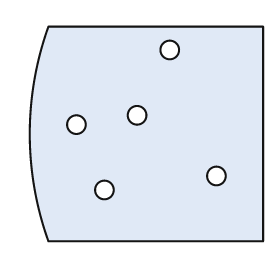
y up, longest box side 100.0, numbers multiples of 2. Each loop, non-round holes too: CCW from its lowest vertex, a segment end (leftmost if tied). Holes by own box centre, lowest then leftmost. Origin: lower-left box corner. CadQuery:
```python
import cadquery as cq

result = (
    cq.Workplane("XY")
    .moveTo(8.0, 0.0)
    .lineTo(100.0, 0.0)
    .lineTo(100.0, 92.0)
    .lineTo(8.0, 92.0)
    .threePointArc((0.0, 46.0), (8.0, 0.0))
    .close()
    .moveTo(32.0, 22.0)
    .circle(4.0)
    .moveTo(80.0, 28.0)
    .circle(4.0)
    .moveTo(20.0, 50.0)
    .circle(4.0)
    .moveTo(46.0, 54.0)
    .circle(4.0)
    .moveTo(60.0, 82.0)
    .circle(4.0)
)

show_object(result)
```